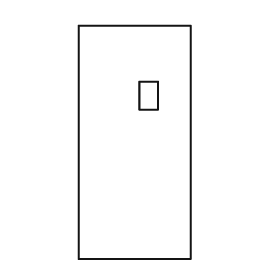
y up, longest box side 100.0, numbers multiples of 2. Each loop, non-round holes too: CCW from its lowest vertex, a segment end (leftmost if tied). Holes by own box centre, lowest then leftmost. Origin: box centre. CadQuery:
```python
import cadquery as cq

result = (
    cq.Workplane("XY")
    .moveTo(-24.0, -50.0)
    .lineTo(24.0, -50.0)
    .lineTo(24.0, 50.0)
    .lineTo(-24.0, 50.0)
    .close()
    .moveTo(2.0, 14.0)
    .lineTo(10.0, 14.0)
    .lineTo(10.0, 26.0)
    .lineTo(2.0, 26.0)
    .close()
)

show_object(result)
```